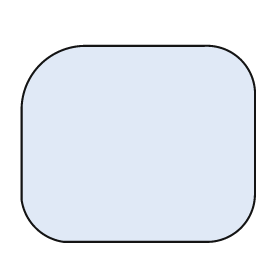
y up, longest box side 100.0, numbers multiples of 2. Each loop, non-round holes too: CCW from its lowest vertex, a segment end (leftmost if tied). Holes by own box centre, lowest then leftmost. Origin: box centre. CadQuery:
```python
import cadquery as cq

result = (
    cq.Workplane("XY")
    .moveTo(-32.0, -42.0)
    .lineTo(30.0, -42.0)
    .threePointArc((44.0, -36.0), (50.0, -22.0))
    .lineTo(50.0, 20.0)
    .threePointArc((44.0, 36.0), (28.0, 42.0))
    .lineTo(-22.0, 42.0)
    .threePointArc((-42.0, 34.0), (-50.0, 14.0))
    .lineTo(-50.0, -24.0)
    .threePointArc((-44.0, -36.0), (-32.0, -42.0))
    .close()
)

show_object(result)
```